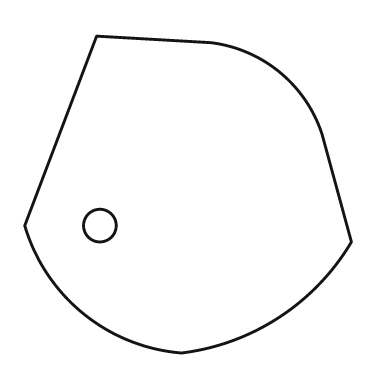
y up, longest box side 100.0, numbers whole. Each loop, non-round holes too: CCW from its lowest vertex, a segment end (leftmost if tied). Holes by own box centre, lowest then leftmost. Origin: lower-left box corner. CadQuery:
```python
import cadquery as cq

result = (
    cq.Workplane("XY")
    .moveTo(48.0, 0.0)
    .threePointArc((78.0, 11.0), (100.0, 34.0))
    .lineTo(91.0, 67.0)
    .threePointArc((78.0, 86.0), (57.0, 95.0))
    .lineTo(22.0, 97.0)
    .lineTo(0.0, 39.0)
    .threePointArc((18.0, 12.0), (48.0, 0.0))
    .close()
    .moveTo(23.0, 39.0)
    .circle(5.0)
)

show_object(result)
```